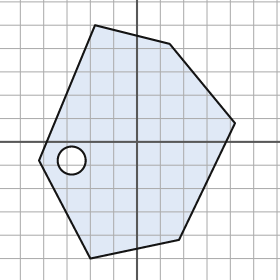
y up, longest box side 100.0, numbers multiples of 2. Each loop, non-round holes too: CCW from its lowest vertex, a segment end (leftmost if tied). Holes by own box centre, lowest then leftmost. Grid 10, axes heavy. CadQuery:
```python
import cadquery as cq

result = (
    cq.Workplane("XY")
    .moveTo(-20.0, -50.0)
    .lineTo(18.0, -42.0)
    .lineTo(42.0, 8.0)
    .lineTo(14.0, 42.0)
    .lineTo(-18.0, 50.0)
    .lineTo(-42.0, -8.0)
    .close()
    .moveTo(-28.0, -8.0)
    .circle(6.0)
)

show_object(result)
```